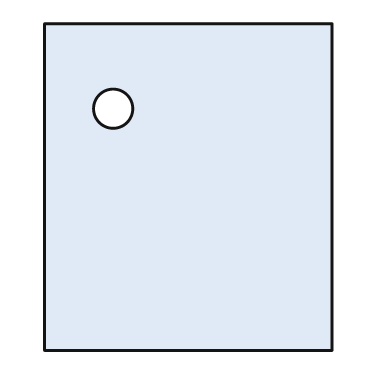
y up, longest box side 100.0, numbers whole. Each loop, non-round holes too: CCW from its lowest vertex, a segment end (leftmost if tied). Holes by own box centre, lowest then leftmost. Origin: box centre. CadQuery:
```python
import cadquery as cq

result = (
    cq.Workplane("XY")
    .moveTo(-44.0, -50.0)
    .lineTo(44.0, -50.0)
    .lineTo(44.0, 50.0)
    .lineTo(-44.0, 50.0)
    .close()
    .moveTo(-23.0, 24.0)
    .circle(6.0)
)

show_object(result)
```